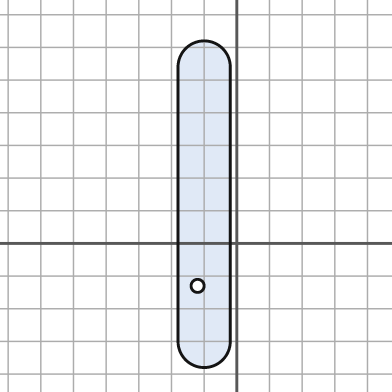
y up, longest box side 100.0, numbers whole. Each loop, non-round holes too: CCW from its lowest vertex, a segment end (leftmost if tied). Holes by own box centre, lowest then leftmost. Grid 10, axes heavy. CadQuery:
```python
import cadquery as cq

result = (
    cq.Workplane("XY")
    .moveTo(-18.0, -30.0)
    .threePointArc((-10.0, -38.0), (-2.0, -30.0))
    .lineTo(-2.0, 54.0)
    .threePointArc((-10.0, 62.0), (-18.0, 54.0))
    .close()
    .moveTo(-12.0, -13.0)
    .circle(2.0)
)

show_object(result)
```